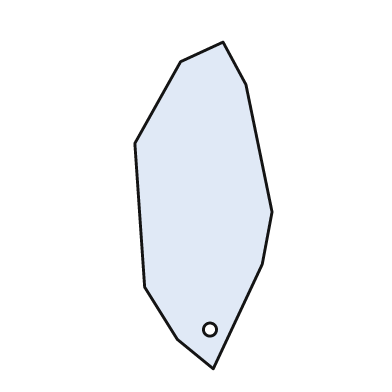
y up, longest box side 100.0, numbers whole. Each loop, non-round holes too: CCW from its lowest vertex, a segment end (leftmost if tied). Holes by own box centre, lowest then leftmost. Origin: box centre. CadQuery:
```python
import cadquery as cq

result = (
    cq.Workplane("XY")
    .moveTo(3.0, -50.0)
    .lineTo(18.0, -18.0)
    .lineTo(21.0, -2.0)
    .lineTo(13.0, 37.0)
    .lineTo(6.0, 50.0)
    .lineTo(-7.0, 44.0)
    .lineTo(-21.0, 19.0)
    .lineTo(-18.0, -25.0)
    .lineTo(-8.0, -41.0)
    .close()
    .moveTo(2.0, -38.0)
    .circle(2.0)
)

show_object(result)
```